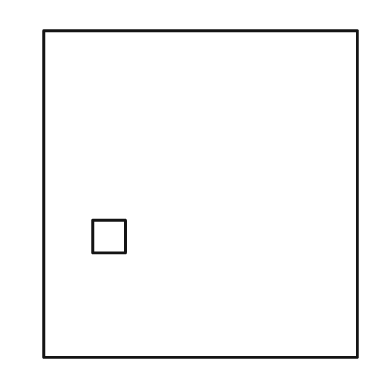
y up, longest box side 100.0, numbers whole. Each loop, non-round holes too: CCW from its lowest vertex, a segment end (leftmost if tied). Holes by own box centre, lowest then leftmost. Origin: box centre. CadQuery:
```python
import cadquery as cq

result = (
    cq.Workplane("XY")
    .moveTo(-48.0, -50.0)
    .lineTo(48.0, -50.0)
    .lineTo(48.0, 50.0)
    .lineTo(-48.0, 50.0)
    .close()
    .moveTo(-33.0, -18.0)
    .lineTo(-23.0, -18.0)
    .lineTo(-23.0, -8.0)
    .lineTo(-33.0, -8.0)
    .close()
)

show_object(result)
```